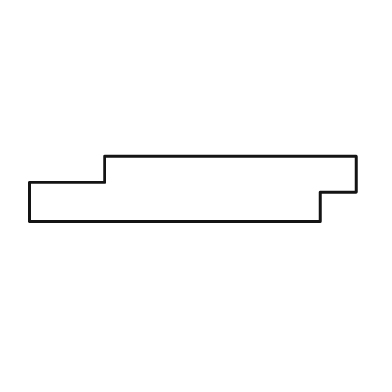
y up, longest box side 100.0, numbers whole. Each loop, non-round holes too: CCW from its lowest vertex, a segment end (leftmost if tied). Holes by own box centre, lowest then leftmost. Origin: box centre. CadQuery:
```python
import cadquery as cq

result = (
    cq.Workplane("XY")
    .moveTo(-50.0, -10.0)
    .lineTo(39.0, -10.0)
    .lineTo(39.0, -1.0)
    .lineTo(50.0, -1.0)
    .lineTo(50.0, 10.0)
    .lineTo(-27.0, 10.0)
    .lineTo(-27.0, 2.0)
    .lineTo(-50.0, 2.0)
    .close()
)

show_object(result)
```